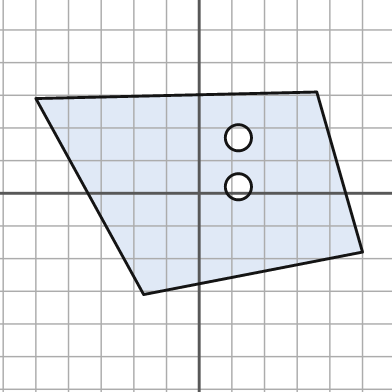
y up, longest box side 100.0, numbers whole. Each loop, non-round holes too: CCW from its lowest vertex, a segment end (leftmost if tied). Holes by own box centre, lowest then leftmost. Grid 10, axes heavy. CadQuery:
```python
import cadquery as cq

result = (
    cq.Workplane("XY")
    .moveTo(-17.0, -31.0)
    .lineTo(50.0, -18.0)
    .lineTo(36.0, 31.0)
    .lineTo(-50.0, 29.0)
    .close()
    .moveTo(12.0, 2.0)
    .circle(4.0)
    .moveTo(12.0, 17.0)
    .circle(4.0)
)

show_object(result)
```